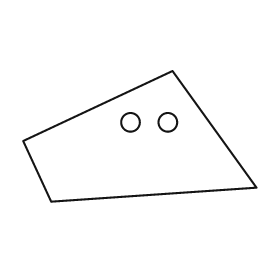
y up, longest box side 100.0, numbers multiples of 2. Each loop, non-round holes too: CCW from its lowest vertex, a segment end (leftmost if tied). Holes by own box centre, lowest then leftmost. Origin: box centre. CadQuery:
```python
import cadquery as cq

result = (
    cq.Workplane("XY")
    .moveTo(-38.0, -28.0)
    .lineTo(50.0, -22.0)
    .lineTo(14.0, 28.0)
    .lineTo(-50.0, -2.0)
    .close()
    .moveTo(-4.0, 6.0)
    .circle(4.0)
    .moveTo(12.0, 6.0)
    .circle(4.0)
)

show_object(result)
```